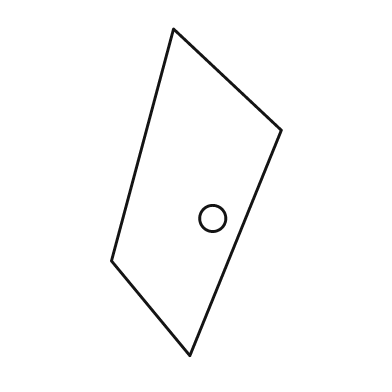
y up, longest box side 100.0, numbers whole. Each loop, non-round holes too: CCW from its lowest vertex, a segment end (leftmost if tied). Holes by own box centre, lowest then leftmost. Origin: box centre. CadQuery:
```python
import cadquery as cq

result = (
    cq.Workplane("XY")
    .moveTo(-2.0, -50.0)
    .lineTo(26.0, 19.0)
    .lineTo(-7.0, 50.0)
    .lineTo(-26.0, -21.0)
    .close()
    .moveTo(5.0, -8.0)
    .circle(4.0)
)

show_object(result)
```